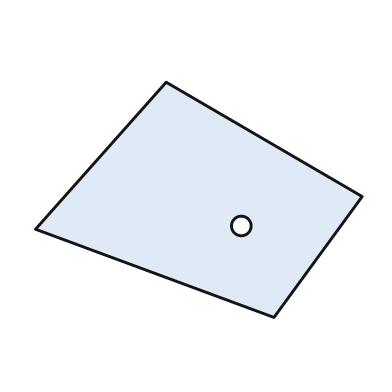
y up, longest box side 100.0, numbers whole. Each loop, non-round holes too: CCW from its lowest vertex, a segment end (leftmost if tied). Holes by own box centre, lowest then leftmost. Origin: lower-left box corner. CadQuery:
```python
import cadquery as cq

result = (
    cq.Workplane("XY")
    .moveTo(73.0, 0.0)
    .lineTo(100.0, 37.0)
    .lineTo(40.0, 72.0)
    .lineTo(0.0, 27.0)
    .close()
    .moveTo(63.0, 28.0)
    .circle(3.0)
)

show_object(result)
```